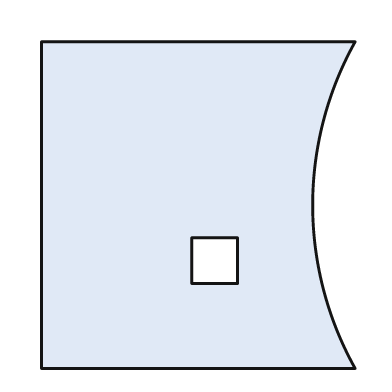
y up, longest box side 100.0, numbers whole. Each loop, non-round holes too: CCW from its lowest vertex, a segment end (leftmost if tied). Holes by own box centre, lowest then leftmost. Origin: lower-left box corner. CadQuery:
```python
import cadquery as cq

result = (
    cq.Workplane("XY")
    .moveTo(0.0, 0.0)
    .lineTo(96.0, 0.0)
    .threePointArc((83.0, 50.0), (96.0, 100.0))
    .lineTo(0.0, 100.0)
    .close()
    .moveTo(46.0, 26.0)
    .lineTo(60.0, 26.0)
    .lineTo(60.0, 40.0)
    .lineTo(46.0, 40.0)
    .close()
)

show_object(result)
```